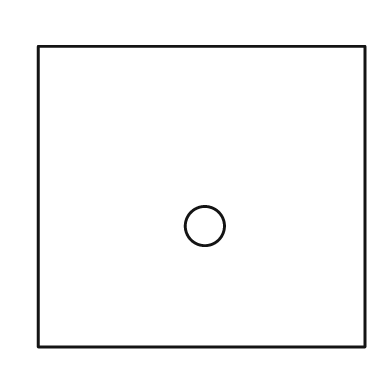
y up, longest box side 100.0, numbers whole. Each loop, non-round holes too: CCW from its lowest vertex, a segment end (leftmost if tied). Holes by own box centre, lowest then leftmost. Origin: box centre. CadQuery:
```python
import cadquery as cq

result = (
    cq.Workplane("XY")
    .moveTo(-50.0, -46.0)
    .lineTo(50.0, -46.0)
    .lineTo(50.0, 46.0)
    .lineTo(-50.0, 46.0)
    .close()
    .moveTo(1.0, -9.0)
    .circle(6.0)
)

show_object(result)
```